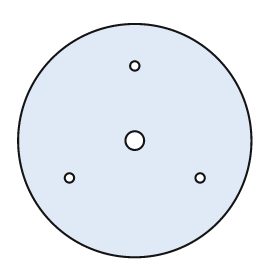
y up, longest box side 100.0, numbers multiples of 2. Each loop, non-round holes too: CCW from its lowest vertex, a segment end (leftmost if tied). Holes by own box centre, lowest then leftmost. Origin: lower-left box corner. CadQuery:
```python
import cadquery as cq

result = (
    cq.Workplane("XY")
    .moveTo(50.0, 50.0)
    .circle(50.0)
    .moveTo(22.0, 34.0)
    .circle(2.0)
    .moveTo(78.0, 34.0)
    .circle(2.0)
    .moveTo(50.0, 50.0)
    .circle(4.0)
    .moveTo(50.0, 82.0)
    .circle(2.0)
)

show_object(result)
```